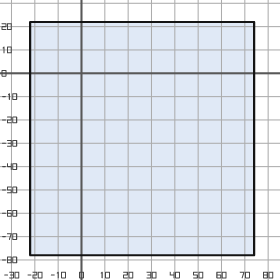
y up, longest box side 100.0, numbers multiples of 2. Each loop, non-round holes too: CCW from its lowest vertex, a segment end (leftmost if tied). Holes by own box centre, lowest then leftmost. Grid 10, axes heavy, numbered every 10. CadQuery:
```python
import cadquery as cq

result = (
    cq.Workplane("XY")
    .moveTo(-22.0, -78.0)
    .lineTo(74.0, -78.0)
    .lineTo(74.0, 22.0)
    .lineTo(-22.0, 22.0)
    .close()
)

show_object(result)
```